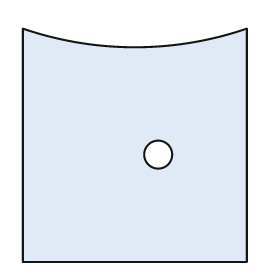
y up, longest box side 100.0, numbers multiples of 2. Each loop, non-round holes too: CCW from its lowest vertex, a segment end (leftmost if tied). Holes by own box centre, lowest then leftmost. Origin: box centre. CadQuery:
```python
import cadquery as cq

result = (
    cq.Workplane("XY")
    .moveTo(-48.0, -50.0)
    .lineTo(48.0, -50.0)
    .lineTo(48.0, 50.0)
    .threePointArc((0.0, 42.0), (-48.0, 50.0))
    .close()
    .moveTo(10.0, -4.0)
    .circle(6.0)
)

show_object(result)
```